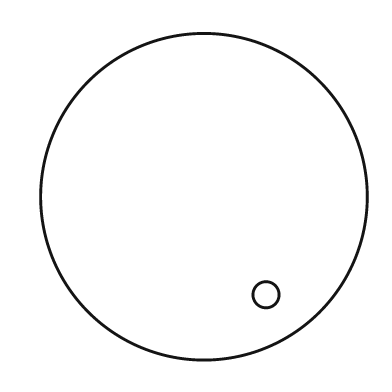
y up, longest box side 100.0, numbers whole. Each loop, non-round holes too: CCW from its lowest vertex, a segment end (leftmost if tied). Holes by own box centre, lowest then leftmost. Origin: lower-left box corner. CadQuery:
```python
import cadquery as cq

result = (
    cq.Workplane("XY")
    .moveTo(50.0, 50.0)
    .circle(50.0)
    .moveTo(69.0, 20.0)
    .circle(4.0)
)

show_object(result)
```